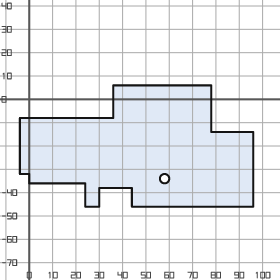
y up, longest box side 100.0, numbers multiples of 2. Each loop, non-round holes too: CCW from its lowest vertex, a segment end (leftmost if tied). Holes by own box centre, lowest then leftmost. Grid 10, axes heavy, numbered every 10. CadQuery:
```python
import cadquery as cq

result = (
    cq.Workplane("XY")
    .moveTo(24.0, -46.0)
    .lineTo(30.0, -46.0)
    .lineTo(30.0, -38.0)
    .lineTo(44.0, -38.0)
    .lineTo(44.0, -46.0)
    .lineTo(96.0, -46.0)
    .lineTo(96.0, -14.0)
    .lineTo(78.0, -14.0)
    .lineTo(78.0, 6.0)
    .lineTo(36.0, 6.0)
    .lineTo(36.0, -8.0)
    .lineTo(-4.0, -8.0)
    .lineTo(-4.0, -32.0)
    .lineTo(0.0, -32.0)
    .lineTo(0.0, -36.0)
    .lineTo(24.0, -36.0)
    .close()
    .moveTo(58.0, -34.0)
    .circle(2.0)
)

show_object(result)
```